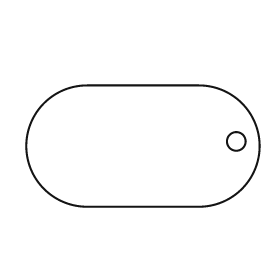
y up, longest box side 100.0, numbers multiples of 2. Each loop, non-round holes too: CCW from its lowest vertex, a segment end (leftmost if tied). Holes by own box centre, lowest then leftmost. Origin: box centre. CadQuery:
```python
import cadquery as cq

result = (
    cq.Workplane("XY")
    .moveTo(-24.0, -26.0)
    .lineTo(24.0, -26.0)
    .threePointArc((50.0, 0.0), (24.0, 26.0))
    .lineTo(-24.0, 26.0)
    .threePointArc((-50.0, 0.0), (-24.0, -26.0))
    .close()
    .moveTo(40.0, 2.0)
    .circle(4.0)
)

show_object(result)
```